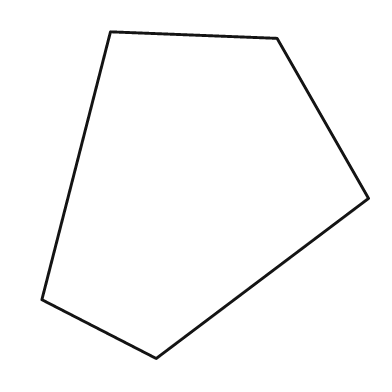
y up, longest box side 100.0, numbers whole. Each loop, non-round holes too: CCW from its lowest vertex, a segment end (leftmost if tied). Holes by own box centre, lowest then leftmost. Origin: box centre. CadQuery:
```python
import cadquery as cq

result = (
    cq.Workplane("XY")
    .moveTo(-15.0, -50.0)
    .lineTo(50.0, -1.0)
    .lineTo(22.0, 48.0)
    .lineTo(-29.0, 50.0)
    .lineTo(-50.0, -32.0)
    .close()
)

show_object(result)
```